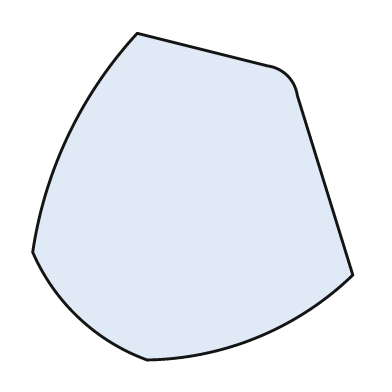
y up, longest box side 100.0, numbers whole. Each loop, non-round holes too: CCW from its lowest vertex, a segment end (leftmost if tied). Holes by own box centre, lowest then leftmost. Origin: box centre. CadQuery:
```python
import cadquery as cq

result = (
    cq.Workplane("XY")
    .moveTo(-14.0, -50.0)
    .threePointArc((20.0, -43.0), (49.0, -24.0))
    .lineTo(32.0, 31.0)
    .threePointArc((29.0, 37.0), (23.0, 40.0))
    .lineTo(-17.0, 50.0)
    .threePointArc((-38.0, 19.0), (-49.0, -17.0))
    .threePointArc((-35.0, -37.0), (-14.0, -50.0))
    .close()
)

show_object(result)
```